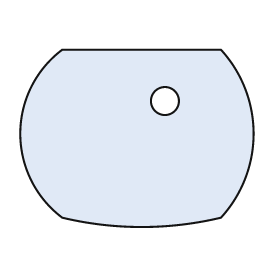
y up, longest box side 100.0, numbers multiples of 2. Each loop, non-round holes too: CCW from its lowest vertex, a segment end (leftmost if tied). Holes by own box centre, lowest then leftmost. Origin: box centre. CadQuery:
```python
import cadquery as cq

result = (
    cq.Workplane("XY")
    .moveTo(-32.0, -34.0)
    .threePointArc((2.0, -38.0), (36.0, -34.0))
    .threePointArc((50.0, 2.0), (36.0, 38.0))
    .lineTo(-32.0, 38.0)
    .threePointArc((-50.0, 2.0), (-32.0, -34.0))
    .close()
    .moveTo(12.0, 16.0)
    .circle(6.0)
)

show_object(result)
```